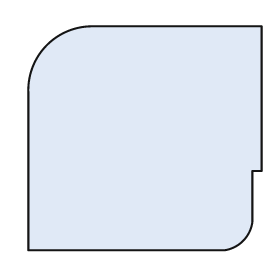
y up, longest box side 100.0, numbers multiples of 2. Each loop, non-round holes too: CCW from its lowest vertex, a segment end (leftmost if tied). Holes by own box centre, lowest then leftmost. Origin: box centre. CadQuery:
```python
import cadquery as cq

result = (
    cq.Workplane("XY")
    .moveTo(-50.0, -48.0)
    .lineTo(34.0, -48.0)
    .threePointArc((42.0, -44.0), (46.0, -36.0))
    .lineTo(46.0, -14.0)
    .lineTo(50.0, -14.0)
    .lineTo(50.0, 48.0)
    .lineTo(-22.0, 48.0)
    .threePointArc((-42.0, 40.0), (-50.0, 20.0))
    .close()
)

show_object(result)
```